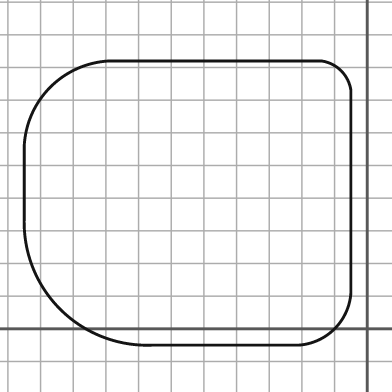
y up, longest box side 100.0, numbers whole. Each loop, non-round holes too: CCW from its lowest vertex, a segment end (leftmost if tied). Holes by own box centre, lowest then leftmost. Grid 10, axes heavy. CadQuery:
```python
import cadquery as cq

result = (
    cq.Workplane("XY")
    .moveTo(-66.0, -5.0)
    .lineTo(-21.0, -5.0)
    .threePointArc((-10.0, 0.0), (-5.0, 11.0))
    .lineTo(-5.0, 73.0)
    .threePointArc((-8.0, 79.0), (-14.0, 82.0))
    .lineTo(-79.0, 82.0)
    .threePointArc((-97.0, 74.0), (-105.0, 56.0))
    .lineTo(-105.0, 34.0)
    .threePointArc((-94.0, 6.0), (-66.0, -5.0))
    .close()
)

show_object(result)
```